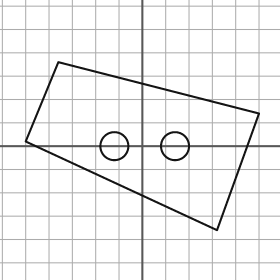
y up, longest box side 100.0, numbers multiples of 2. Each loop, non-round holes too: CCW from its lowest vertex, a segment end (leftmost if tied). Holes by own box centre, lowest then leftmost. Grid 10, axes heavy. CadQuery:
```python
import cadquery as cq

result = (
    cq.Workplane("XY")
    .moveTo(32.0, -36.0)
    .lineTo(50.0, 14.0)
    .lineTo(-36.0, 36.0)
    .lineTo(-50.0, 2.0)
    .close()
    .moveTo(-12.0, 0.0)
    .circle(6.0)
    .moveTo(14.0, 0.0)
    .circle(6.0)
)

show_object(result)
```